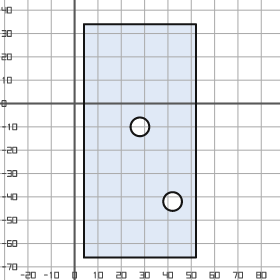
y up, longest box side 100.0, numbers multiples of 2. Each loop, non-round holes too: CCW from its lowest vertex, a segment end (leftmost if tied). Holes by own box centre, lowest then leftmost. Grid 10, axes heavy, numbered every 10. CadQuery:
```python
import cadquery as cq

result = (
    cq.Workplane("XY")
    .moveTo(4.0, -66.0)
    .lineTo(52.0, -66.0)
    .lineTo(52.0, 34.0)
    .lineTo(4.0, 34.0)
    .close()
    .moveTo(42.0, -42.0)
    .circle(4.0)
    .moveTo(28.0, -10.0)
    .circle(4.0)
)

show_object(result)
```